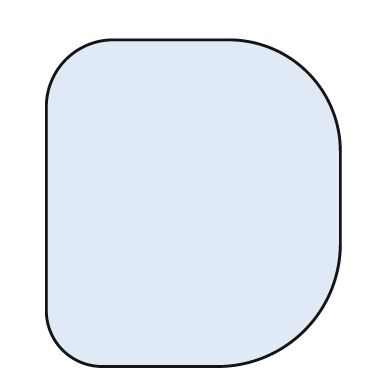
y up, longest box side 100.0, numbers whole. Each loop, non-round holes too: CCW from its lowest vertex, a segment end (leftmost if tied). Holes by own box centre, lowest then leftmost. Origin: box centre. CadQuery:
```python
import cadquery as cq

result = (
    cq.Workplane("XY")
    .moveTo(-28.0, -50.0)
    .lineTo(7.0, -50.0)
    .threePointArc((34.0, -39.0), (45.0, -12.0))
    .lineTo(45.0, 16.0)
    .threePointArc((35.0, 40.0), (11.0, 50.0))
    .lineTo(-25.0, 50.0)
    .threePointArc((-39.0, 44.0), (-45.0, 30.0))
    .lineTo(-45.0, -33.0)
    .threePointArc((-40.0, -45.0), (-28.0, -50.0))
    .close()
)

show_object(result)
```